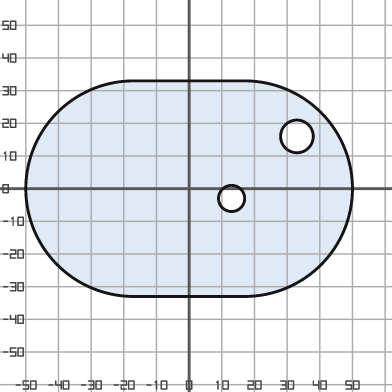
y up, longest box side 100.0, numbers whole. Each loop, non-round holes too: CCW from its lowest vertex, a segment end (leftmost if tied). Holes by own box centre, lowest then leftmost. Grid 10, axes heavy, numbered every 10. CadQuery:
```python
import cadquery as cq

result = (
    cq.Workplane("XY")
    .moveTo(-17.0, -33.0)
    .lineTo(17.0, -33.0)
    .threePointArc((50.0, 0.0), (17.0, 33.0))
    .lineTo(-17.0, 33.0)
    .threePointArc((-50.0, 0.0), (-17.0, -33.0))
    .close()
    .moveTo(13.0, -3.0)
    .circle(4.0)
    .moveTo(33.0, 16.0)
    .circle(5.0)
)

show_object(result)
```